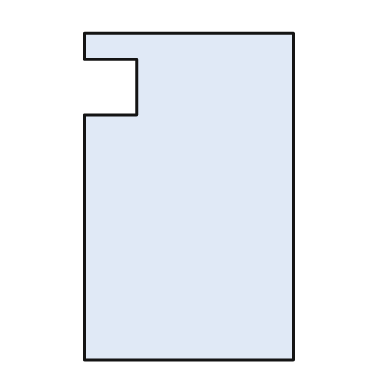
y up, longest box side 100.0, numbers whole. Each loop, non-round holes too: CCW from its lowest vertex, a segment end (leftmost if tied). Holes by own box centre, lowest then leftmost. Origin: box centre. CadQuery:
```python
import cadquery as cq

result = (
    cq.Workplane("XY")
    .moveTo(-32.0, -50.0)
    .lineTo(32.0, -50.0)
    .lineTo(32.0, 50.0)
    .lineTo(-32.0, 50.0)
    .lineTo(-32.0, 42.0)
    .lineTo(-16.0, 42.0)
    .lineTo(-16.0, 25.0)
    .lineTo(-32.0, 25.0)
    .close()
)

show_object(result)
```